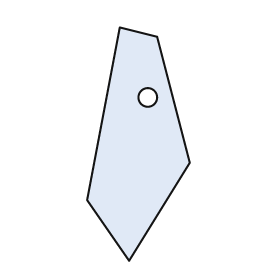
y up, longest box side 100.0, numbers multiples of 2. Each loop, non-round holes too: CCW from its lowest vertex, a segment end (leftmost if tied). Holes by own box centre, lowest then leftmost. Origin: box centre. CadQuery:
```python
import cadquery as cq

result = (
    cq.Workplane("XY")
    .moveTo(-4.0, -50.0)
    .lineTo(22.0, -8.0)
    .lineTo(8.0, 46.0)
    .lineTo(-8.0, 50.0)
    .lineTo(-22.0, -24.0)
    .close()
    .moveTo(4.0, 20.0)
    .circle(4.0)
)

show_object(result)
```